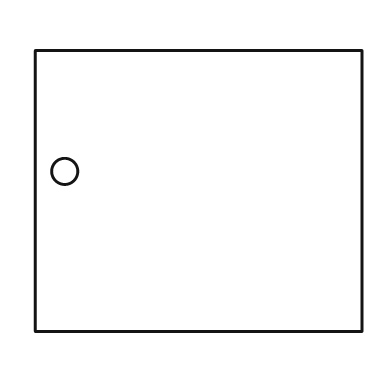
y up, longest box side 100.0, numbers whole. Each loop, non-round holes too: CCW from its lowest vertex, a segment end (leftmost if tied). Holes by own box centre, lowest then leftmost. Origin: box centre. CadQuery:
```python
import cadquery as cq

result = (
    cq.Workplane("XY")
    .moveTo(-50.0, -43.0)
    .lineTo(50.0, -43.0)
    .lineTo(50.0, 43.0)
    .lineTo(-50.0, 43.0)
    .close()
    .moveTo(-41.0, 6.0)
    .circle(4.0)
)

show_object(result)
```